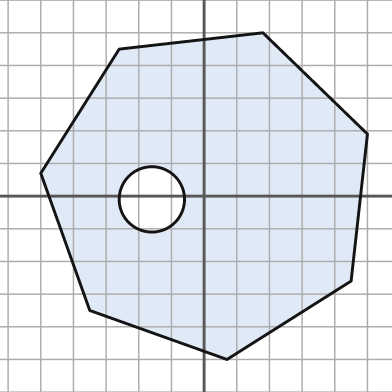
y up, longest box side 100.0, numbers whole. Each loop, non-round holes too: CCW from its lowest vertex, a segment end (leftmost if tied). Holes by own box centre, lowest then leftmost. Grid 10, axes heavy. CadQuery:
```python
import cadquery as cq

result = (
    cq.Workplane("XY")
    .moveTo(7.0, -50.0)
    .lineTo(45.0, -26.0)
    .lineTo(50.0, 19.0)
    .lineTo(18.0, 50.0)
    .lineTo(-26.0, 45.0)
    .lineTo(-50.0, 7.0)
    .lineTo(-35.0, -35.0)
    .close()
    .moveTo(-16.0, -1.0)
    .circle(10.0)
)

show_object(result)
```